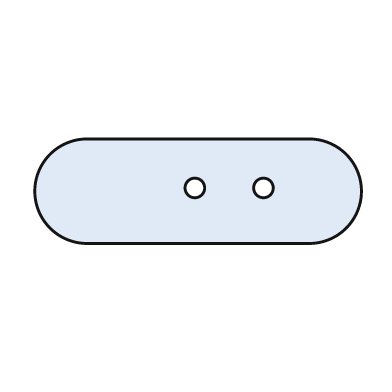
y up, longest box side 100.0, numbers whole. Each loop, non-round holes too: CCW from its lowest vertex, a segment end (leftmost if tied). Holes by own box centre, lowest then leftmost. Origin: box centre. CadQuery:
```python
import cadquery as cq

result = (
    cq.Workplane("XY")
    .moveTo(-34.0, -16.0)
    .lineTo(34.0, -16.0)
    .threePointArc((50.0, 0.0), (34.0, 16.0))
    .lineTo(-34.0, 16.0)
    .threePointArc((-50.0, 0.0), (-34.0, -16.0))
    .close()
    .moveTo(-1.0, 1.0)
    .circle(3.0)
    .moveTo(20.0, 1.0)
    .circle(3.0)
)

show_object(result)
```